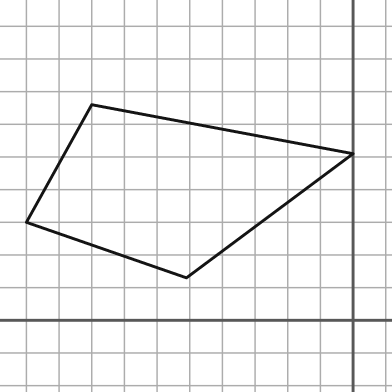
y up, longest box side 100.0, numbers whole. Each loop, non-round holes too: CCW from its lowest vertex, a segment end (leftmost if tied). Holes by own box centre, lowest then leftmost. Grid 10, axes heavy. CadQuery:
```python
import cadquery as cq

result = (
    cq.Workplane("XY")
    .moveTo(-51.0, 13.0)
    .lineTo(0.0, 51.0)
    .lineTo(-80.0, 66.0)
    .lineTo(-100.0, 30.0)
    .close()
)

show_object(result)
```